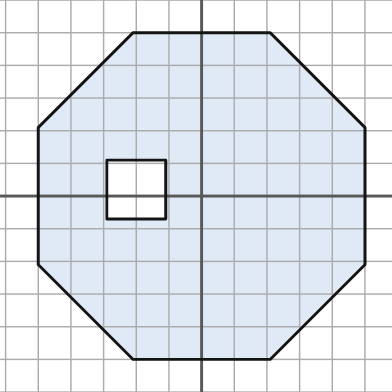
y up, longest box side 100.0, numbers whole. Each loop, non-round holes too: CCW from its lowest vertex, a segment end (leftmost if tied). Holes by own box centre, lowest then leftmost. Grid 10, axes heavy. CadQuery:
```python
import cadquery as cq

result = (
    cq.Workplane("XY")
    .moveTo(-21.0, -50.0)
    .lineTo(21.0, -50.0)
    .lineTo(50.0, -21.0)
    .lineTo(50.0, 21.0)
    .lineTo(21.0, 50.0)
    .lineTo(-21.0, 50.0)
    .lineTo(-50.0, 21.0)
    .lineTo(-50.0, -21.0)
    .close()
    .moveTo(-29.0, -7.0)
    .lineTo(-11.0, -7.0)
    .lineTo(-11.0, 11.0)
    .lineTo(-29.0, 11.0)
    .close()
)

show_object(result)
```